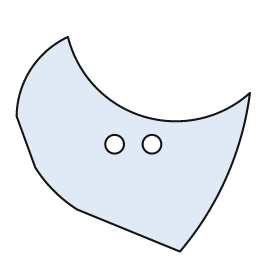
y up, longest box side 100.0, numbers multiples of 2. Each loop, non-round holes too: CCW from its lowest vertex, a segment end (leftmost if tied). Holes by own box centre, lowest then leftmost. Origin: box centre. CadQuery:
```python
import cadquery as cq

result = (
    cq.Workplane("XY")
    .moveTo(20.0, -46.0)
    .threePointArc((40.0, -14.0), (50.0, 22.0))
    .threePointArc((4.0, 12.0), (-28.0, 46.0))
    .threePointArc((-44.0, 32.0), (-50.0, 12.0))
    .lineTo(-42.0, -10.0)
    .threePointArc((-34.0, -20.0), (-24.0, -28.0))
    .close()
    .moveTo(-8.0, 0.0)
    .circle(4.0)
    .moveTo(8.0, 0.0)
    .circle(4.0)
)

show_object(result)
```